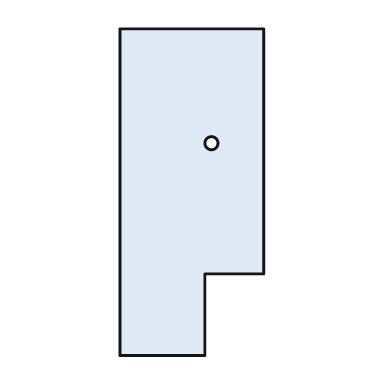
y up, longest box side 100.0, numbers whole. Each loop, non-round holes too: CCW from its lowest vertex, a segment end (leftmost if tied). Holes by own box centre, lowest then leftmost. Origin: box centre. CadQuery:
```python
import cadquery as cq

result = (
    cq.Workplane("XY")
    .moveTo(-22.0, -50.0)
    .lineTo(4.0, -50.0)
    .lineTo(4.0, -25.0)
    .lineTo(22.0, -25.0)
    .lineTo(22.0, 50.0)
    .lineTo(-22.0, 50.0)
    .close()
    .moveTo(6.0, 15.0)
    .circle(2.0)
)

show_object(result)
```